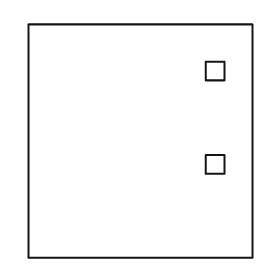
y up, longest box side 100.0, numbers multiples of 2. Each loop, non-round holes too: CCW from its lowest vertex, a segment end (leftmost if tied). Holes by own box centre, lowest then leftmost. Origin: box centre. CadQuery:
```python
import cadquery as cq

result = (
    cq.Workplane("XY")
    .moveTo(-48.0, -50.0)
    .lineTo(48.0, -50.0)
    .lineTo(48.0, 50.0)
    .lineTo(-48.0, 50.0)
    .close()
    .moveTo(28.0, -14.0)
    .lineTo(36.0, -14.0)
    .lineTo(36.0, -6.0)
    .lineTo(28.0, -6.0)
    .close()
    .moveTo(28.0, 26.0)
    .lineTo(36.0, 26.0)
    .lineTo(36.0, 34.0)
    .lineTo(28.0, 34.0)
    .close()
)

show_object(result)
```